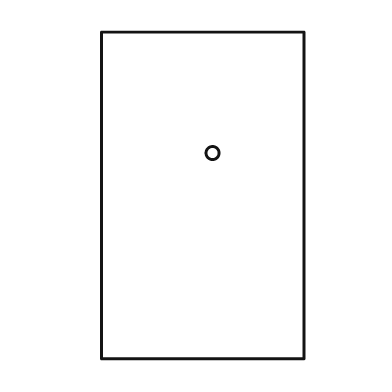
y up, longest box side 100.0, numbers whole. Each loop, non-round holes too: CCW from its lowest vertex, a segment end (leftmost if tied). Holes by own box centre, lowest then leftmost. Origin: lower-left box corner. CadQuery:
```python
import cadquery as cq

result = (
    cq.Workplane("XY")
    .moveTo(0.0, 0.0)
    .lineTo(62.0, 0.0)
    .lineTo(62.0, 100.0)
    .lineTo(0.0, 100.0)
    .close()
    .moveTo(34.0, 63.0)
    .circle(2.0)
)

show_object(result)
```